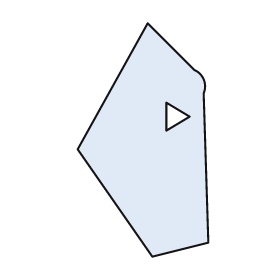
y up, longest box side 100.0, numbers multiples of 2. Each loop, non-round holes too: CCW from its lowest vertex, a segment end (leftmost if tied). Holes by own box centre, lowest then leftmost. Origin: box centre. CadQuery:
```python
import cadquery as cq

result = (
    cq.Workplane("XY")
    .moveTo(4.0, -50.0)
    .lineTo(28.0, -44.0)
    .lineTo(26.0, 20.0)
    .threePointArc((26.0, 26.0), (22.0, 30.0))
    .lineTo(2.0, 50.0)
    .lineTo(-28.0, -4.0)
    .close()
    .moveTo(10.0, 4.0)
    .lineTo(20.0, 10.0)
    .lineTo(10.0, 16.0)
    .close()
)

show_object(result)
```